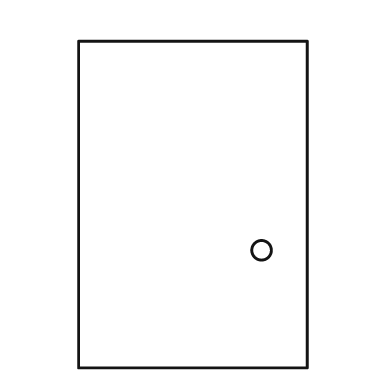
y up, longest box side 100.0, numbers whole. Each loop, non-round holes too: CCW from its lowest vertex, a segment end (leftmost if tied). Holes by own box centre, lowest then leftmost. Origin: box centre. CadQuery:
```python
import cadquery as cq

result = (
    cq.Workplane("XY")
    .moveTo(-35.0, -50.0)
    .lineTo(35.0, -50.0)
    .lineTo(35.0, 50.0)
    .lineTo(-35.0, 50.0)
    .close()
    .moveTo(21.0, -14.0)
    .circle(3.0)
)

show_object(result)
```